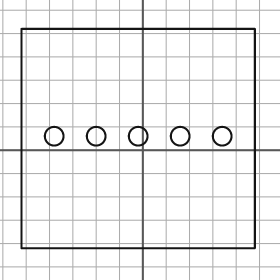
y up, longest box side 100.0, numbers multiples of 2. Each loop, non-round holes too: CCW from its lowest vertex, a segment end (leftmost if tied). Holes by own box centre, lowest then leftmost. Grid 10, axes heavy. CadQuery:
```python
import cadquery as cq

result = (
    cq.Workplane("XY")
    .moveTo(-52.0, -42.0)
    .lineTo(48.0, -42.0)
    .lineTo(48.0, 52.0)
    .lineTo(-52.0, 52.0)
    .close()
    .moveTo(-38.0, 6.0)
    .circle(4.0)
    .moveTo(-20.0, 6.0)
    .circle(4.0)
    .moveTo(-2.0, 6.0)
    .circle(4.0)
    .moveTo(16.0, 6.0)
    .circle(4.0)
    .moveTo(34.0, 6.0)
    .circle(4.0)
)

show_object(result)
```